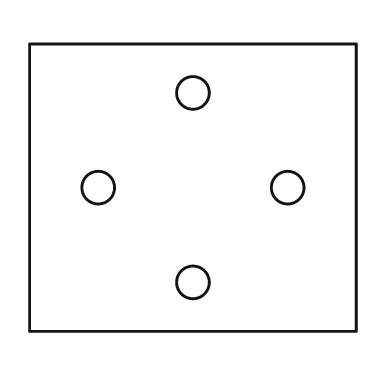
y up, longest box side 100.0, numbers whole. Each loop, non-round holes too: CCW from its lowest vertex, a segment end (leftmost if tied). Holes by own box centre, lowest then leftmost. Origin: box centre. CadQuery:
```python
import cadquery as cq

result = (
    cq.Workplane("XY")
    .moveTo(-50.0, -44.0)
    .lineTo(50.0, -44.0)
    .lineTo(50.0, 44.0)
    .lineTo(-50.0, 44.0)
    .close()
    .moveTo(0.0, -29.0)
    .circle(5.0)
    .moveTo(-29.0, 0.0)
    .circle(5.0)
    .moveTo(29.0, 0.0)
    .circle(5.0)
    .moveTo(0.0, 29.0)
    .circle(5.0)
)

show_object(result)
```